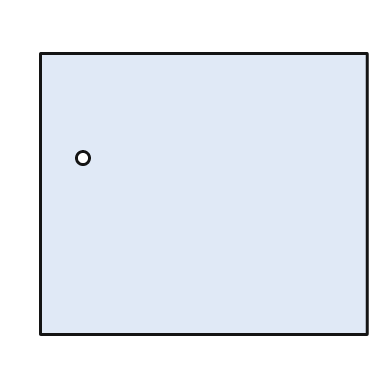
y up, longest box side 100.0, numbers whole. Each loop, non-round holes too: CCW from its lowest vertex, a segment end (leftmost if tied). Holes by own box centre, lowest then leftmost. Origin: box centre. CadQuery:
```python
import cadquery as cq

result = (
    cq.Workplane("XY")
    .moveTo(-50.0, -43.0)
    .lineTo(50.0, -43.0)
    .lineTo(50.0, 43.0)
    .lineTo(-50.0, 43.0)
    .close()
    .moveTo(-37.0, 11.0)
    .circle(2.0)
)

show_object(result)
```